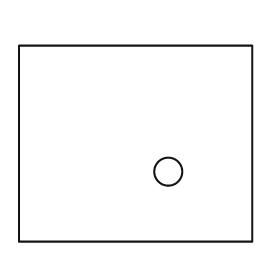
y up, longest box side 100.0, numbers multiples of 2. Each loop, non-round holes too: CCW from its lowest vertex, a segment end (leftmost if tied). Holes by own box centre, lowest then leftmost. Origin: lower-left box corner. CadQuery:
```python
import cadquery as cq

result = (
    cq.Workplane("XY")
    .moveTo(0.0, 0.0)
    .lineTo(100.0, 0.0)
    .lineTo(100.0, 84.0)
    .lineTo(0.0, 84.0)
    .close()
    .moveTo(64.0, 30.0)
    .circle(6.0)
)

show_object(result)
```